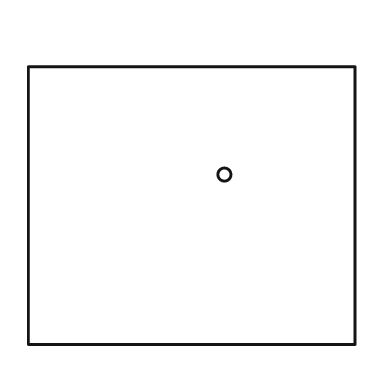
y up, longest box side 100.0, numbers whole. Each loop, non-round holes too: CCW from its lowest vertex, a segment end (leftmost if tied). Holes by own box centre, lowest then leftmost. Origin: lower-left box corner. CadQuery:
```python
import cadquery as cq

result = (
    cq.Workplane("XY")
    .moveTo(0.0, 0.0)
    .lineTo(100.0, 0.0)
    .lineTo(100.0, 85.0)
    .lineTo(0.0, 85.0)
    .close()
    .moveTo(60.0, 52.0)
    .circle(2.0)
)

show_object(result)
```